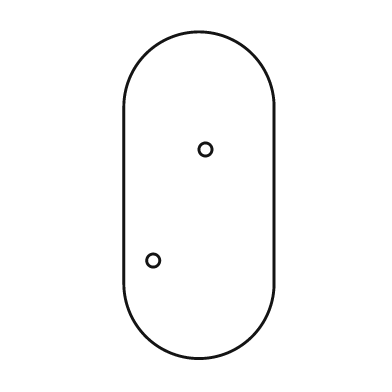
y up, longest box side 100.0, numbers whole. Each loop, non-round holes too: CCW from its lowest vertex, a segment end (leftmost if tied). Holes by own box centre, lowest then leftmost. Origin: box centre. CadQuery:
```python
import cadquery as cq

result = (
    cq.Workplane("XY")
    .moveTo(-23.0, -27.0)
    .threePointArc((0.0, -50.0), (23.0, -27.0))
    .lineTo(23.0, 27.0)
    .threePointArc((0.0, 50.0), (-23.0, 27.0))
    .close()
    .moveTo(-14.0, -20.0)
    .circle(2.0)
    .moveTo(2.0, 14.0)
    .circle(2.0)
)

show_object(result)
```